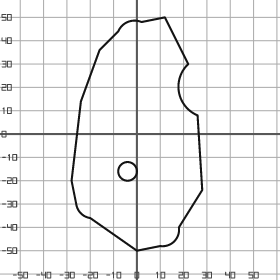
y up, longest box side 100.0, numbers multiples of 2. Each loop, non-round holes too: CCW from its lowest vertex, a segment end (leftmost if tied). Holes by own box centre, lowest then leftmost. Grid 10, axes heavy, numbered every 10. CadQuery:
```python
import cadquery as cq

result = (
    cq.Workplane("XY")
    .moveTo(0.0, -50.0)
    .lineTo(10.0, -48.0)
    .threePointArc((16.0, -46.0), (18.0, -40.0))
    .lineTo(28.0, -24.0)
    .lineTo(26.0, 8.0)
    .threePointArc((18.0, 18.0), (22.0, 30.0))
    .lineTo(12.0, 50.0)
    .lineTo(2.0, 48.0)
    .threePointArc((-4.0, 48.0), (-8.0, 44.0))
    .lineTo(-16.0, 36.0)
    .lineTo(-24.0, 14.0)
    .lineTo(-28.0, -20.0)
    .lineTo(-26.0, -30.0)
    .threePointArc((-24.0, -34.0), (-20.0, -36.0))
    .close()
    .moveTo(-4.0, -16.0)
    .circle(4.0)
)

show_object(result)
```